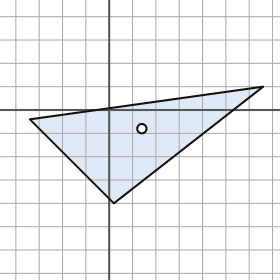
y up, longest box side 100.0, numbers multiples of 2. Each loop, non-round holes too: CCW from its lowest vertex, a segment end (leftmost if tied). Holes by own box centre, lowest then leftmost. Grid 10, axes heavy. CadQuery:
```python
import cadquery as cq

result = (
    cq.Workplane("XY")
    .moveTo(2.0, -40.0)
    .lineTo(66.0, 10.0)
    .lineTo(-34.0, -4.0)
    .close()
    .moveTo(14.0, -8.0)
    .circle(2.0)
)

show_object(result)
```